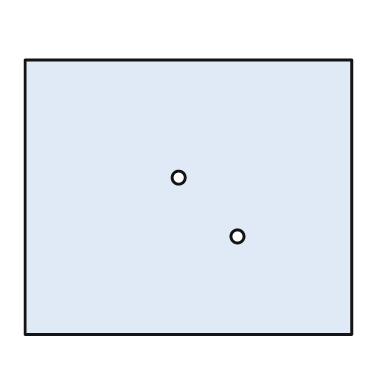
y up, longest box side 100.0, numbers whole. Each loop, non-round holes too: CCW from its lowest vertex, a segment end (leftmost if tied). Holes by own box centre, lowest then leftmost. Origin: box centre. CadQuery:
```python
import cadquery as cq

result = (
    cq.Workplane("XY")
    .moveTo(-50.0, -42.0)
    .lineTo(50.0, -42.0)
    .lineTo(50.0, 42.0)
    .lineTo(-50.0, 42.0)
    .close()
    .moveTo(15.0, -12.0)
    .circle(2.0)
    .moveTo(-3.0, 6.0)
    .circle(2.0)
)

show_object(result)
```